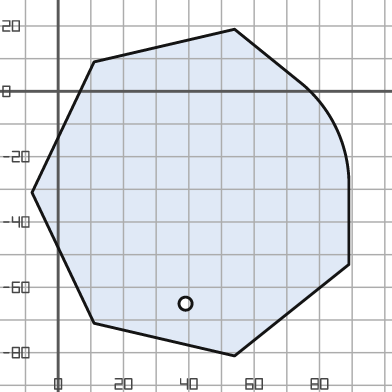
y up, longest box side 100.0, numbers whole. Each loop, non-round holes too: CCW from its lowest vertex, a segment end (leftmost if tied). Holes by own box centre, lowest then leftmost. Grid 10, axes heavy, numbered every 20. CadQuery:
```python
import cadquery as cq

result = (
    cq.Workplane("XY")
    .moveTo(54.0, -81.0)
    .lineTo(89.0, -53.0)
    .lineTo(89.0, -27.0)
    .threePointArc((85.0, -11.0), (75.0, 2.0))
    .lineTo(54.0, 19.0)
    .lineTo(11.0, 9.0)
    .lineTo(-8.0, -31.0)
    .lineTo(11.0, -71.0)
    .close()
    .moveTo(39.0, -65.0)
    .circle(2.0)
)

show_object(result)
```